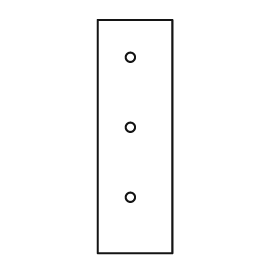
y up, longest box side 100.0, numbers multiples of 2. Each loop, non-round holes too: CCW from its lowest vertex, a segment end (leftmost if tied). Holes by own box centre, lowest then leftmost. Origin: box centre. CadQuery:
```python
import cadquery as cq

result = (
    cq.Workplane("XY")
    .moveTo(-16.0, -50.0)
    .lineTo(16.0, -50.0)
    .lineTo(16.0, 50.0)
    .lineTo(-16.0, 50.0)
    .close()
    .moveTo(-2.0, -26.0)
    .circle(2.0)
    .moveTo(-2.0, 4.0)
    .circle(2.0)
    .moveTo(-2.0, 34.0)
    .circle(2.0)
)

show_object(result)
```